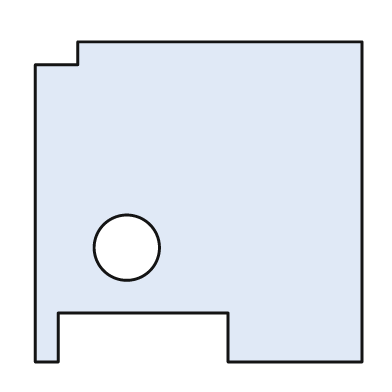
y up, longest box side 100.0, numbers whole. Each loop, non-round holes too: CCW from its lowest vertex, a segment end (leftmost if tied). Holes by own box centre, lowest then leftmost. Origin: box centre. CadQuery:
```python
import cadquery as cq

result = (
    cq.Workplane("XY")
    .moveTo(-50.0, -49.0)
    .lineTo(-43.0, -49.0)
    .lineTo(-43.0, -34.0)
    .lineTo(9.0, -34.0)
    .lineTo(9.0, -49.0)
    .lineTo(50.0, -49.0)
    .lineTo(50.0, 49.0)
    .lineTo(-37.0, 49.0)
    .lineTo(-37.0, 42.0)
    .lineTo(-50.0, 42.0)
    .close()
    .moveTo(-22.0, -14.0)
    .circle(10.0)
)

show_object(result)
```